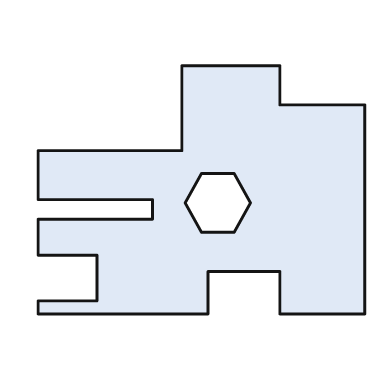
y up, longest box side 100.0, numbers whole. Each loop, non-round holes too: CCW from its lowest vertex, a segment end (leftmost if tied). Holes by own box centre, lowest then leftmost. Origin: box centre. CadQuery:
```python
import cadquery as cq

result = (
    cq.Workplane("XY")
    .moveTo(-50.0, -38.0)
    .lineTo(2.0, -38.0)
    .lineTo(2.0, -25.0)
    .lineTo(24.0, -25.0)
    .lineTo(24.0, -38.0)
    .lineTo(50.0, -38.0)
    .lineTo(50.0, 26.0)
    .lineTo(24.0, 26.0)
    .lineTo(24.0, 38.0)
    .lineTo(-6.0, 38.0)
    .lineTo(-6.0, 12.0)
    .lineTo(-50.0, 12.0)
    .lineTo(-50.0, -3.0)
    .lineTo(-15.0, -3.0)
    .lineTo(-15.0, -9.0)
    .lineTo(-50.0, -9.0)
    .lineTo(-50.0, -20.0)
    .lineTo(-32.0, -20.0)
    .lineTo(-32.0, -34.0)
    .lineTo(-50.0, -34.0)
    .close()
    .moveTo(0.0, -13.0)
    .lineTo(10.0, -13.0)
    .lineTo(15.0, -4.0)
    .lineTo(10.0, 5.0)
    .lineTo(0.0, 5.0)
    .lineTo(-5.0, -4.0)
    .close()
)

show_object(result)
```